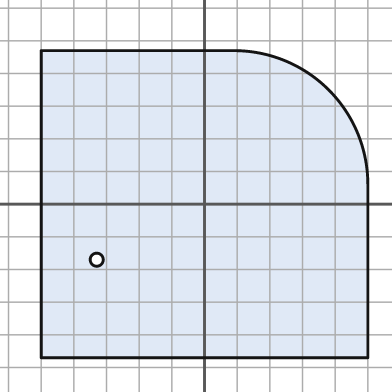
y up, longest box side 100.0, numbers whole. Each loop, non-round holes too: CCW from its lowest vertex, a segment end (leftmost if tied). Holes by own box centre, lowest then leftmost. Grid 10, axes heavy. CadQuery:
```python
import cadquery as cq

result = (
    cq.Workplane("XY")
    .moveTo(-50.0, -47.0)
    .lineTo(50.0, -47.0)
    .lineTo(50.0, 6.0)
    .threePointArc((38.0, 35.0), (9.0, 47.0))
    .lineTo(-50.0, 47.0)
    .close()
    .moveTo(-33.0, -17.0)
    .circle(2.0)
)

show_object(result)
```